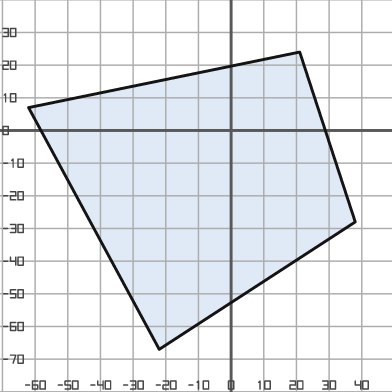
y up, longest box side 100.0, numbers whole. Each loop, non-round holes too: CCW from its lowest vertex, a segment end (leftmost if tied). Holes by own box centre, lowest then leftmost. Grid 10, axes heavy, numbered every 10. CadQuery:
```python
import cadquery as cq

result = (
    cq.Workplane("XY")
    .moveTo(-22.0, -67.0)
    .lineTo(38.0, -28.0)
    .lineTo(21.0, 24.0)
    .lineTo(-62.0, 7.0)
    .close()
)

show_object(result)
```